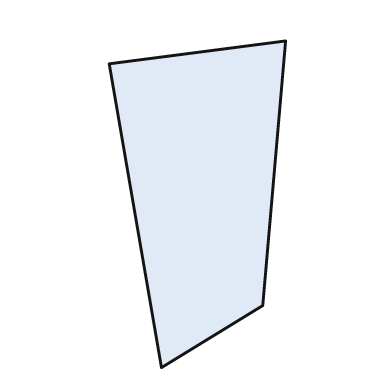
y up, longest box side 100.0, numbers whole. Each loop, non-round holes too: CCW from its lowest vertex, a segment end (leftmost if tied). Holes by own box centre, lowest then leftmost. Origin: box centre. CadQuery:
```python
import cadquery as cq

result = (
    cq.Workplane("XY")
    .moveTo(-11.0, -50.0)
    .lineTo(20.0, -31.0)
    .lineTo(27.0, 50.0)
    .lineTo(-27.0, 43.0)
    .close()
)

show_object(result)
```